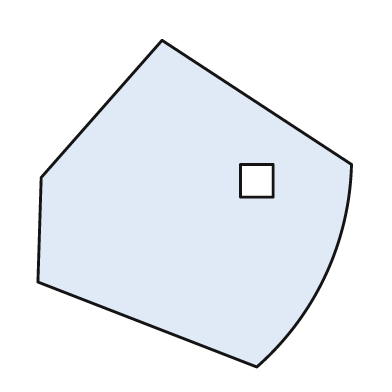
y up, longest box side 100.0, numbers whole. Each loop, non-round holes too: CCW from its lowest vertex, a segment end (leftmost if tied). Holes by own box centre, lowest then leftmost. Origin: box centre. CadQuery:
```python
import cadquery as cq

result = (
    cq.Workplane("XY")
    .moveTo(19.0, -50.0)
    .threePointArc((40.0, -22.0), (48.0, 12.0))
    .lineTo(-10.0, 50.0)
    .lineTo(-47.0, 8.0)
    .lineTo(-48.0, -24.0)
    .close()
    .moveTo(14.0, 2.0)
    .lineTo(24.0, 2.0)
    .lineTo(24.0, 12.0)
    .lineTo(14.0, 12.0)
    .close()
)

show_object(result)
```